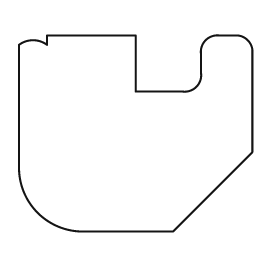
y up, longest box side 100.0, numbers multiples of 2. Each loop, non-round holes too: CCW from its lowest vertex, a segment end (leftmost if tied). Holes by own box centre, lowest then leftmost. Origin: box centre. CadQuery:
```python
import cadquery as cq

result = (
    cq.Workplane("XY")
    .moveTo(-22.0, -42.0)
    .lineTo(16.0, -42.0)
    .lineTo(50.0, -8.0)
    .lineTo(50.0, 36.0)
    .threePointArc((48.0, 40.0), (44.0, 42.0))
    .lineTo(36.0, 42.0)
    .threePointArc((30.0, 40.0), (28.0, 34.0))
    .lineTo(28.0, 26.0)
    .threePointArc((26.0, 20.0), (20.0, 18.0))
    .lineTo(0.0, 18.0)
    .lineTo(0.0, 42.0)
    .lineTo(-38.0, 42.0)
    .lineTo(-38.0, 38.0)
    .threePointArc((-44.0, 40.0), (-50.0, 38.0))
    .lineTo(-50.0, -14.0)
    .threePointArc((-42.0, -34.0), (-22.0, -42.0))
    .close()
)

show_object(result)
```